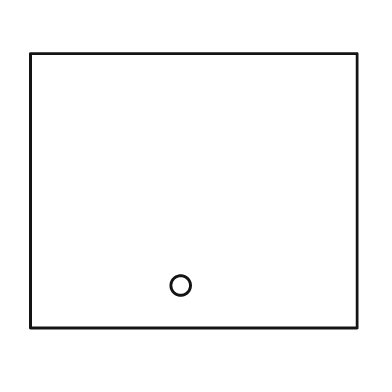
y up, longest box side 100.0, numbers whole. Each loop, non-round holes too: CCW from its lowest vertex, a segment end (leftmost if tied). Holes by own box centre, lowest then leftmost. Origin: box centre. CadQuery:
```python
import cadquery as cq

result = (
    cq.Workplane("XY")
    .moveTo(-50.0, -42.0)
    .lineTo(50.0, -42.0)
    .lineTo(50.0, 42.0)
    .lineTo(-50.0, 42.0)
    .close()
    .moveTo(-4.0, -29.0)
    .circle(3.0)
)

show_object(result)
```